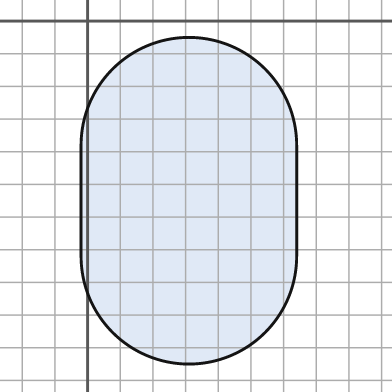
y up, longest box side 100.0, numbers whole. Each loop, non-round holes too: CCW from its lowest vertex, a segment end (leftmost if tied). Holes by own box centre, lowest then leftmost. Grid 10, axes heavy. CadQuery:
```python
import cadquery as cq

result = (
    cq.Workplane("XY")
    .moveTo(-2.0, -72.0)
    .threePointArc((31.0, -105.0), (64.0, -72.0))
    .lineTo(64.0, -38.0)
    .threePointArc((31.0, -5.0), (-2.0, -38.0))
    .close()
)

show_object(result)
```